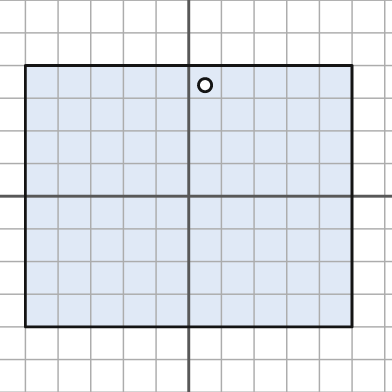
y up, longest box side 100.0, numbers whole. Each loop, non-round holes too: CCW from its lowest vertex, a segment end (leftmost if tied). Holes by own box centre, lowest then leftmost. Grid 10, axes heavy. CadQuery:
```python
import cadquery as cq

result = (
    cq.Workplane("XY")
    .moveTo(-50.0, -40.0)
    .lineTo(50.0, -40.0)
    .lineTo(50.0, 40.0)
    .lineTo(-50.0, 40.0)
    .close()
    .moveTo(5.0, 34.0)
    .circle(2.0)
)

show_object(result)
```